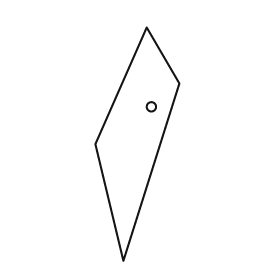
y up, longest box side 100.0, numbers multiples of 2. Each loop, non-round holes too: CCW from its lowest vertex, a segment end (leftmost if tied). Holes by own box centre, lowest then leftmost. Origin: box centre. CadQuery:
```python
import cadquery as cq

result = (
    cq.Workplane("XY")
    .moveTo(-6.0, -50.0)
    .lineTo(18.0, 26.0)
    .lineTo(4.0, 50.0)
    .lineTo(-18.0, 0.0)
    .close()
    .moveTo(6.0, 16.0)
    .circle(2.0)
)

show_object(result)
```